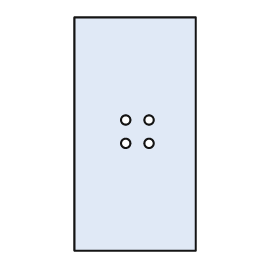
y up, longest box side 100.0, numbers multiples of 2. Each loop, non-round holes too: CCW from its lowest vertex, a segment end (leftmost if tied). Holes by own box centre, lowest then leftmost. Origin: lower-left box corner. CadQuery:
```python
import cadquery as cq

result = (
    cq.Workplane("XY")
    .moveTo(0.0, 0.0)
    .lineTo(52.0, 0.0)
    .lineTo(52.0, 100.0)
    .lineTo(0.0, 100.0)
    .close()
    .moveTo(22.0, 46.0)
    .circle(2.0)
    .moveTo(32.0, 46.0)
    .circle(2.0)
    .moveTo(22.0, 56.0)
    .circle(2.0)
    .moveTo(32.0, 56.0)
    .circle(2.0)
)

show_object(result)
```